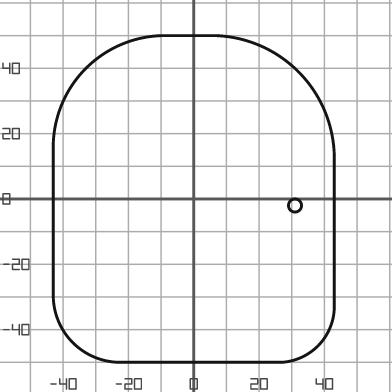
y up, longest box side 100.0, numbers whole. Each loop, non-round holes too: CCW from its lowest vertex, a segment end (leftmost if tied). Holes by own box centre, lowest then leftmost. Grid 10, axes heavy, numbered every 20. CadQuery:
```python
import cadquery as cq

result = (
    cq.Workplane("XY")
    .moveTo(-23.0, -50.0)
    .lineTo(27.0, -50.0)
    .threePointArc((38.0, -45.0), (43.0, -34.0))
    .lineTo(43.0, 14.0)
    .threePointArc((32.0, 39.0), (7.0, 50.0))
    .lineTo(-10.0, 50.0)
    .threePointArc((-33.0, 40.0), (-43.0, 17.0))
    .lineTo(-43.0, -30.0)
    .threePointArc((-37.0, -44.0), (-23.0, -50.0))
    .close()
    .moveTo(31.0, -2.0)
    .circle(2.0)
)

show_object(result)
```